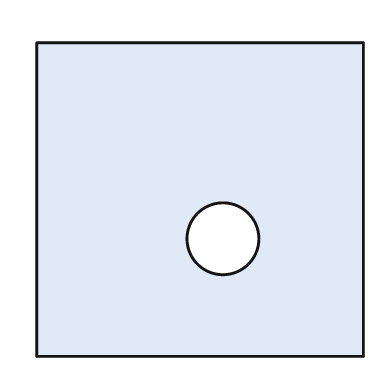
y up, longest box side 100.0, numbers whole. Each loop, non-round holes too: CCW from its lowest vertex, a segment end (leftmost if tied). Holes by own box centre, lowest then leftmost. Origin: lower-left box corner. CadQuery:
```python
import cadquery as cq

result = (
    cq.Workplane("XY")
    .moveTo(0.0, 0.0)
    .lineTo(100.0, 0.0)
    .lineTo(100.0, 96.0)
    .lineTo(0.0, 96.0)
    .close()
    .moveTo(57.0, 36.0)
    .circle(11.0)
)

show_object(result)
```